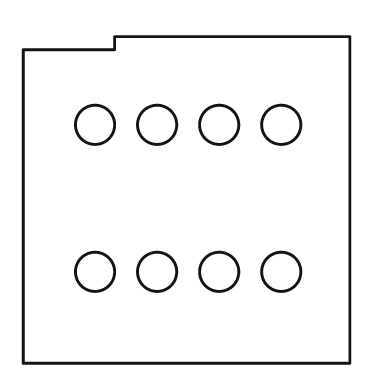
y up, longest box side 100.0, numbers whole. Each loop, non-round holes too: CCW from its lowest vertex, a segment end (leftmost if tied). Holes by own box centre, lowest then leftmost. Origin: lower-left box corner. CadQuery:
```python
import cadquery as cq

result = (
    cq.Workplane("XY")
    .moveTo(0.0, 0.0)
    .lineTo(100.0, 0.0)
    .lineTo(100.0, 100.0)
    .lineTo(28.0, 100.0)
    .lineTo(28.0, 96.0)
    .lineTo(0.0, 96.0)
    .close()
    .moveTo(22.0, 28.0)
    .circle(6.0)
    .moveTo(41.0, 28.0)
    .circle(6.0)
    .moveTo(60.0, 28.0)
    .circle(6.0)
    .moveTo(79.0, 28.0)
    .circle(6.0)
    .moveTo(22.0, 73.0)
    .circle(6.0)
    .moveTo(41.0, 73.0)
    .circle(6.0)
    .moveTo(60.0, 73.0)
    .circle(6.0)
    .moveTo(79.0, 73.0)
    .circle(6.0)
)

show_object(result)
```